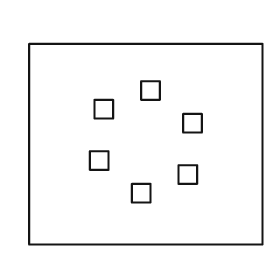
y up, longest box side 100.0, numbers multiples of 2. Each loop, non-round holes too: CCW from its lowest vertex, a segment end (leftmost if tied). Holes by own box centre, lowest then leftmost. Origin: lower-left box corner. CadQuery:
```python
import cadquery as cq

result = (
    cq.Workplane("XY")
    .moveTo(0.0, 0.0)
    .lineTo(100.0, 0.0)
    .lineTo(100.0, 86.0)
    .lineTo(0.0, 86.0)
    .close()
    .moveTo(44.0, 18.0)
    .lineTo(52.0, 18.0)
    .lineTo(52.0, 26.0)
    .lineTo(44.0, 26.0)
    .close()
    .moveTo(64.0, 26.0)
    .lineTo(72.0, 26.0)
    .lineTo(72.0, 34.0)
    .lineTo(64.0, 34.0)
    .close()
    .moveTo(26.0, 32.0)
    .lineTo(34.0, 32.0)
    .lineTo(34.0, 40.0)
    .lineTo(26.0, 40.0)
    .close()
    .moveTo(66.0, 48.0)
    .lineTo(74.0, 48.0)
    .lineTo(74.0, 56.0)
    .lineTo(66.0, 56.0)
    .close()
    .moveTo(28.0, 54.0)
    .lineTo(36.0, 54.0)
    .lineTo(36.0, 62.0)
    .lineTo(28.0, 62.0)
    .close()
    .moveTo(48.0, 62.0)
    .lineTo(56.0, 62.0)
    .lineTo(56.0, 70.0)
    .lineTo(48.0, 70.0)
    .close()
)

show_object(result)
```